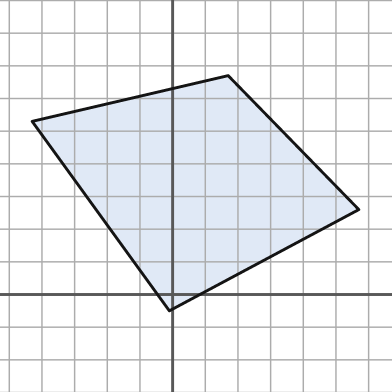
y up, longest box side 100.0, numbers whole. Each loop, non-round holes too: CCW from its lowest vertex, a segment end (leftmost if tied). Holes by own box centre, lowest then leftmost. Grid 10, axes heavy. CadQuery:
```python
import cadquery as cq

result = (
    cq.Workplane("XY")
    .moveTo(-1.0, -5.0)
    .lineTo(57.0, 26.0)
    .lineTo(17.0, 67.0)
    .lineTo(-43.0, 53.0)
    .close()
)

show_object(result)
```